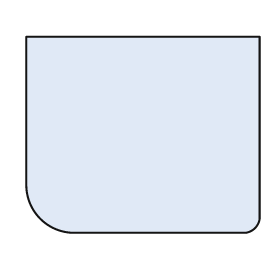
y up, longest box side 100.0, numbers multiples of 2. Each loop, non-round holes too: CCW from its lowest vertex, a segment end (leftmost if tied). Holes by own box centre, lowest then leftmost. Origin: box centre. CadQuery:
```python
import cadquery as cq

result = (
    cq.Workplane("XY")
    .moveTo(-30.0, -42.0)
    .lineTo(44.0, -42.0)
    .threePointArc((48.0, -40.0), (50.0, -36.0))
    .lineTo(50.0, 42.0)
    .lineTo(-50.0, 42.0)
    .lineTo(-50.0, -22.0)
    .threePointArc((-44.0, -36.0), (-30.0, -42.0))
    .close()
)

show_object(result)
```